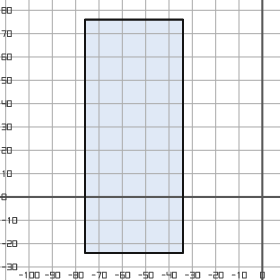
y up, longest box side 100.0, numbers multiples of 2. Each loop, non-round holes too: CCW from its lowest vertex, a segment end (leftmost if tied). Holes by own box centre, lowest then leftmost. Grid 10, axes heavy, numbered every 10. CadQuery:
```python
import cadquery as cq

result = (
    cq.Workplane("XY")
    .moveTo(-76.0, -24.0)
    .lineTo(-34.0, -24.0)
    .lineTo(-34.0, 76.0)
    .lineTo(-76.0, 76.0)
    .close()
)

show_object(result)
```